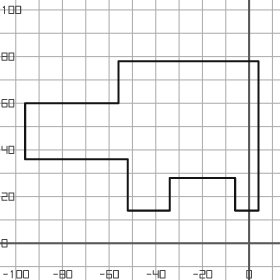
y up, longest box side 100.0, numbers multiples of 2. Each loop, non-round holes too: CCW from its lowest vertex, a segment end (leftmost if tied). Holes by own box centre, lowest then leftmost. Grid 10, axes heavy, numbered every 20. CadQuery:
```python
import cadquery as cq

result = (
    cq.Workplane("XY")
    .moveTo(-52.0, 14.0)
    .lineTo(-34.0, 14.0)
    .lineTo(-34.0, 28.0)
    .lineTo(-6.0, 28.0)
    .lineTo(-6.0, 14.0)
    .lineTo(4.0, 14.0)
    .lineTo(4.0, 78.0)
    .lineTo(-56.0, 78.0)
    .lineTo(-56.0, 60.0)
    .lineTo(-96.0, 60.0)
    .lineTo(-96.0, 36.0)
    .lineTo(-52.0, 36.0)
    .close()
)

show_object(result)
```